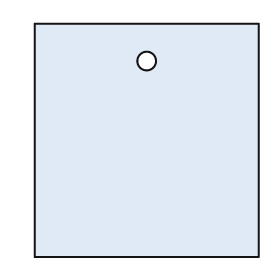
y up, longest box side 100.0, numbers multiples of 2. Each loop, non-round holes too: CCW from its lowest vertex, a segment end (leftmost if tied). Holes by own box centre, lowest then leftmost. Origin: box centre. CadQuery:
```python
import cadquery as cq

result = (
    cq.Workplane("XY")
    .moveTo(-48.0, -50.0)
    .lineTo(48.0, -50.0)
    .lineTo(48.0, 50.0)
    .lineTo(-48.0, 50.0)
    .close()
    .moveTo(0.0, 34.0)
    .circle(4.0)
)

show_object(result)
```